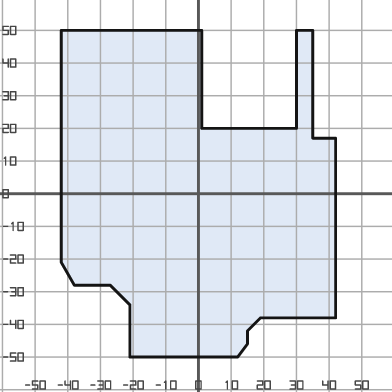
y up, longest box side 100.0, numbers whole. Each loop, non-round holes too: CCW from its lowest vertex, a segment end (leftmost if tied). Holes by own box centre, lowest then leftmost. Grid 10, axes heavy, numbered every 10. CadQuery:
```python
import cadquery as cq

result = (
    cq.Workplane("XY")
    .moveTo(-21.0, -50.0)
    .lineTo(12.0, -50.0)
    .lineTo(15.0, -46.0)
    .lineTo(15.0, -42.0)
    .lineTo(19.0, -38.0)
    .lineTo(42.0, -38.0)
    .lineTo(42.0, 17.0)
    .lineTo(35.0, 17.0)
    .lineTo(35.0, 50.0)
    .lineTo(30.0, 50.0)
    .lineTo(30.0, 20.0)
    .lineTo(1.0, 20.0)
    .lineTo(1.0, 50.0)
    .lineTo(-42.0, 50.0)
    .lineTo(-42.0, -21.0)
    .lineTo(-38.0, -28.0)
    .lineTo(-27.0, -28.0)
    .lineTo(-21.0, -34.0)
    .close()
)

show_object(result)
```